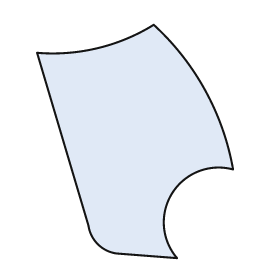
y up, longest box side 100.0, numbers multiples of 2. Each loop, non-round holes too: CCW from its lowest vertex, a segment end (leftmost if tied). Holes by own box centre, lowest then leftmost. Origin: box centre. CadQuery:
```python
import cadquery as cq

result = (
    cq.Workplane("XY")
    .moveTo(18.0, -50.0)
    .threePointArc((16.0, -22.0), (42.0, -12.0))
    .threePointArc((30.0, 22.0), (8.0, 50.0))
    .threePointArc((-16.0, 40.0), (-42.0, 38.0))
    .lineTo(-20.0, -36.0)
    .threePointArc((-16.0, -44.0), (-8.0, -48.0))
    .close()
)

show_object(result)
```